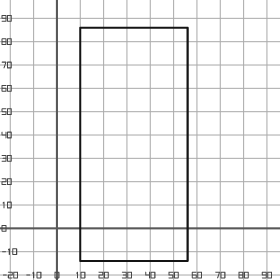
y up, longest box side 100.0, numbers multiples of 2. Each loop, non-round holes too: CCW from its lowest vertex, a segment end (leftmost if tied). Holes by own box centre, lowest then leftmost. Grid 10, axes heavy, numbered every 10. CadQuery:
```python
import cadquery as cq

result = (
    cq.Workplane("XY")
    .moveTo(10.0, -14.0)
    .lineTo(56.0, -14.0)
    .lineTo(56.0, 86.0)
    .lineTo(10.0, 86.0)
    .close()
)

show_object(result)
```